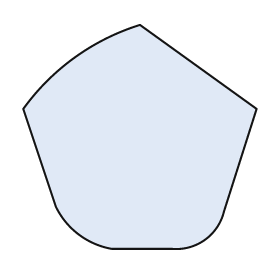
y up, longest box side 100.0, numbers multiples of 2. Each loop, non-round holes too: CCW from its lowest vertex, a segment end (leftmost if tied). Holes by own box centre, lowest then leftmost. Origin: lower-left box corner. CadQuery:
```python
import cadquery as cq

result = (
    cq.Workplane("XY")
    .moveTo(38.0, 0.0)
    .lineTo(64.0, 0.0)
    .threePointArc((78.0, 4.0), (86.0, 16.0))
    .lineTo(100.0, 60.0)
    .lineTo(50.0, 96.0)
    .threePointArc((22.0, 82.0), (0.0, 60.0))
    .lineTo(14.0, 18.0)
    .threePointArc((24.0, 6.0), (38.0, 0.0))
    .close()
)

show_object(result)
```